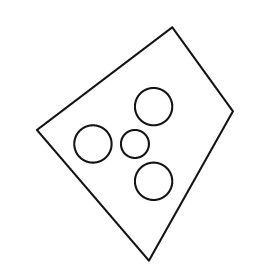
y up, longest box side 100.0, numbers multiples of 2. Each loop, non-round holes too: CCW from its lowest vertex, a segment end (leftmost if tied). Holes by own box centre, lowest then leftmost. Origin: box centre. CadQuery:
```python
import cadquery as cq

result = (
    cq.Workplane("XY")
    .moveTo(6.0, -50.0)
    .lineTo(42.0, 14.0)
    .lineTo(16.0, 50.0)
    .lineTo(-42.0, 6.0)
    .close()
    .moveTo(8.0, -16.0)
    .circle(8.0)
    .moveTo(-18.0, 0.0)
    .circle(8.0)
    .moveTo(0.0, 0.0)
    .circle(6.0)
    .moveTo(8.0, 16.0)
    .circle(8.0)
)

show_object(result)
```